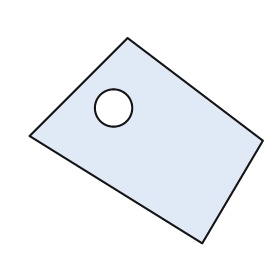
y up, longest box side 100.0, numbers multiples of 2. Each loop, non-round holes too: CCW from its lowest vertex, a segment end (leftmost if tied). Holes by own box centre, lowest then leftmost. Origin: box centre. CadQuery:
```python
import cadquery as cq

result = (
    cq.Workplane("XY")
    .moveTo(24.0, -44.0)
    .lineTo(50.0, 0.0)
    .lineTo(-8.0, 44.0)
    .lineTo(-50.0, 2.0)
    .close()
    .moveTo(-14.0, 14.0)
    .circle(8.0)
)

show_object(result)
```